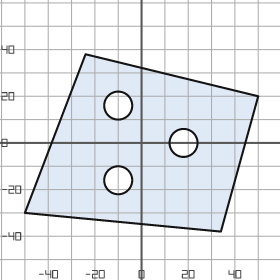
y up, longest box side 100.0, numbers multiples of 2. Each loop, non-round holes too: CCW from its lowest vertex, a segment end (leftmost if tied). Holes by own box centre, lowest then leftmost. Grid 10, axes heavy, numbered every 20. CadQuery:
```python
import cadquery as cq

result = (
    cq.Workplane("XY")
    .moveTo(34.0, -38.0)
    .lineTo(50.0, 20.0)
    .lineTo(-24.0, 38.0)
    .lineTo(-50.0, -30.0)
    .close()
    .moveTo(-10.0, -16.0)
    .circle(6.0)
    .moveTo(18.0, 0.0)
    .circle(6.0)
    .moveTo(-10.0, 16.0)
    .circle(6.0)
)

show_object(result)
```